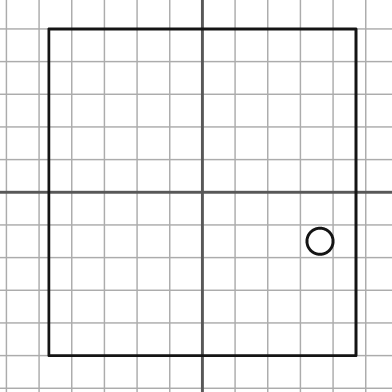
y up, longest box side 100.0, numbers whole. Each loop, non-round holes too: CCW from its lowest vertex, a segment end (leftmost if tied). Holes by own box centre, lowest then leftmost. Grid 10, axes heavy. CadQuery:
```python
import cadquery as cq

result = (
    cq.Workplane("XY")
    .moveTo(-47.0, -50.0)
    .lineTo(47.0, -50.0)
    .lineTo(47.0, 50.0)
    .lineTo(-47.0, 50.0)
    .close()
    .moveTo(36.0, -15.0)
    .circle(4.0)
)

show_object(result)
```